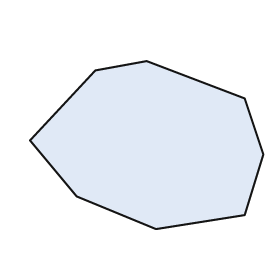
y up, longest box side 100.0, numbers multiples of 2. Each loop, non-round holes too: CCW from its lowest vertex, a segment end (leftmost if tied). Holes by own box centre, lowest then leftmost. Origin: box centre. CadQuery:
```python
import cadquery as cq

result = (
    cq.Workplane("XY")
    .moveTo(4.0, -36.0)
    .lineTo(42.0, -30.0)
    .lineTo(50.0, -4.0)
    .lineTo(42.0, 20.0)
    .lineTo(0.0, 36.0)
    .lineTo(-22.0, 32.0)
    .lineTo(-50.0, 2.0)
    .lineTo(-30.0, -22.0)
    .close()
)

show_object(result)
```